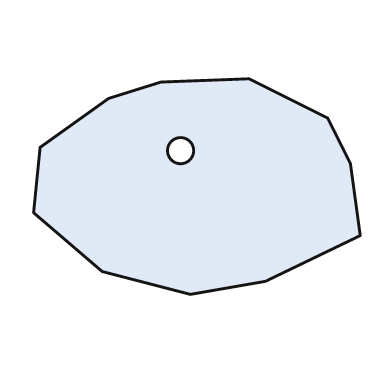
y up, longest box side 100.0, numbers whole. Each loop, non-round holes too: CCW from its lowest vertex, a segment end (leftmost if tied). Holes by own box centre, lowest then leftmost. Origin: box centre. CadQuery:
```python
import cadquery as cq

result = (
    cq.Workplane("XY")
    .moveTo(-2.0, -33.0)
    .lineTo(21.0, -29.0)
    .lineTo(50.0, -15.0)
    .lineTo(47.0, 7.0)
    .lineTo(40.0, 21.0)
    .lineTo(16.0, 33.0)
    .lineTo(-11.0, 32.0)
    .lineTo(-27.0, 27.0)
    .lineTo(-48.0, 12.0)
    .lineTo(-50.0, -8.0)
    .lineTo(-29.0, -26.0)
    .close()
    .moveTo(-5.0, 11.0)
    .circle(4.0)
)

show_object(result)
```